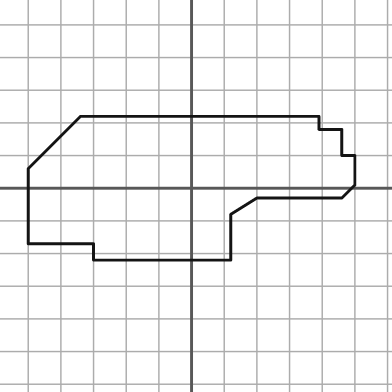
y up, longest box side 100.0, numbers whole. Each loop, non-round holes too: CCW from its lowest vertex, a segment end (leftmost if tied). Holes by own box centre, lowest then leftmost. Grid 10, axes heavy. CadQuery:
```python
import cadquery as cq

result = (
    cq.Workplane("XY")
    .moveTo(-30.0, -22.0)
    .lineTo(12.0, -22.0)
    .lineTo(12.0, -8.0)
    .lineTo(20.0, -3.0)
    .lineTo(46.0, -3.0)
    .lineTo(50.0, 1.0)
    .lineTo(50.0, 10.0)
    .lineTo(46.0, 10.0)
    .lineTo(46.0, 18.0)
    .lineTo(39.0, 18.0)
    .lineTo(39.0, 22.0)
    .lineTo(-34.0, 22.0)
    .lineTo(-50.0, 6.0)
    .lineTo(-50.0, -17.0)
    .lineTo(-30.0, -17.0)
    .close()
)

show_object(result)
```